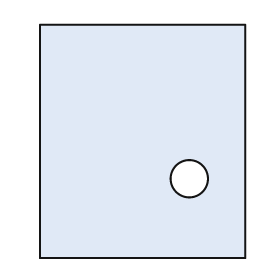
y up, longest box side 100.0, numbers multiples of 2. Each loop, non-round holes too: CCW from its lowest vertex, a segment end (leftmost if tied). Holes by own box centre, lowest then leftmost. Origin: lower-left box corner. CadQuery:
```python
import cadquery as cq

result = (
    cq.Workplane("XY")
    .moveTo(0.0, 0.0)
    .lineTo(88.0, 0.0)
    .lineTo(88.0, 100.0)
    .lineTo(0.0, 100.0)
    .close()
    .moveTo(64.0, 34.0)
    .circle(8.0)
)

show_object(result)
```